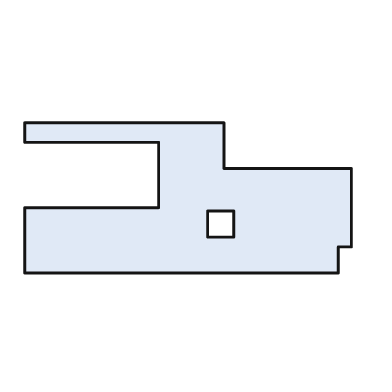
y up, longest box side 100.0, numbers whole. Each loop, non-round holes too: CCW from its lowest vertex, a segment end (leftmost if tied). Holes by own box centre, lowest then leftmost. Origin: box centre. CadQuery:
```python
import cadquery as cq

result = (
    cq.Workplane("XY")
    .moveTo(-50.0, -23.0)
    .lineTo(46.0, -23.0)
    .lineTo(46.0, -15.0)
    .lineTo(50.0, -15.0)
    .lineTo(50.0, 9.0)
    .lineTo(11.0, 9.0)
    .lineTo(11.0, 23.0)
    .lineTo(-50.0, 23.0)
    .lineTo(-50.0, 17.0)
    .lineTo(-9.0, 17.0)
    .lineTo(-9.0, -3.0)
    .lineTo(-50.0, -3.0)
    .close()
    .moveTo(6.0, -12.0)
    .lineTo(14.0, -12.0)
    .lineTo(14.0, -4.0)
    .lineTo(6.0, -4.0)
    .close()
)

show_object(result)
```